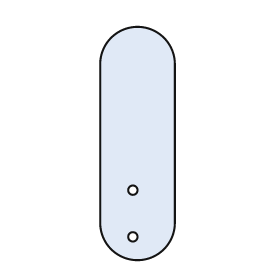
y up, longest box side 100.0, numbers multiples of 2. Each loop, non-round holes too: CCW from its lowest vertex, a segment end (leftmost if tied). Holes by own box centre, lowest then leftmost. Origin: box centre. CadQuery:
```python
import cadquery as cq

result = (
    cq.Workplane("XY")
    .moveTo(-16.0, -34.0)
    .threePointArc((0.0, -50.0), (16.0, -34.0))
    .lineTo(16.0, 34.0)
    .threePointArc((0.0, 50.0), (-16.0, 34.0))
    .close()
    .moveTo(-2.0, -40.0)
    .circle(2.0)
    .moveTo(-2.0, -20.0)
    .circle(2.0)
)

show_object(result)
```